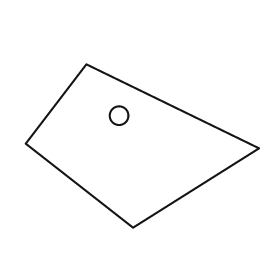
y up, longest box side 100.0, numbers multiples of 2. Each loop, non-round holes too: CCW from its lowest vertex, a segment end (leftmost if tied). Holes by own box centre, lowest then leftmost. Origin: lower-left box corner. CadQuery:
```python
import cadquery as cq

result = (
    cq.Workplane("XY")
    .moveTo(46.0, 0.0)
    .lineTo(100.0, 34.0)
    .lineTo(26.0, 70.0)
    .lineTo(0.0, 36.0)
    .close()
    .moveTo(40.0, 48.0)
    .circle(4.0)
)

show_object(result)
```